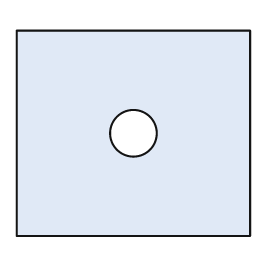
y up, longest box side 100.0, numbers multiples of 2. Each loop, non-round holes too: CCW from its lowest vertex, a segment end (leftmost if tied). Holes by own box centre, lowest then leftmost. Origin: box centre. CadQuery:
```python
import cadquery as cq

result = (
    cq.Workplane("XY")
    .moveTo(-50.0, -44.0)
    .lineTo(50.0, -44.0)
    .lineTo(50.0, 44.0)
    .lineTo(-50.0, 44.0)
    .close()
    .moveTo(0.0, 0.0)
    .circle(10.0)
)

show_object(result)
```